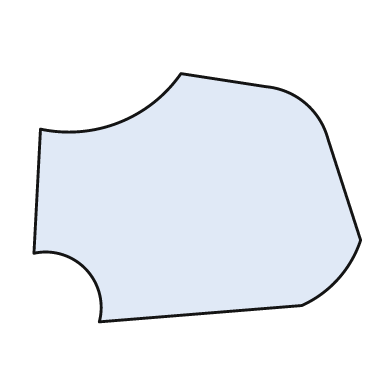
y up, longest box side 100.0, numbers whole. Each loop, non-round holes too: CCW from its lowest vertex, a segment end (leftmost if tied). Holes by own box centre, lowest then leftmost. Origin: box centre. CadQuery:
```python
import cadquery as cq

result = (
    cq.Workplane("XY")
    .moveTo(-30.0, -38.0)
    .lineTo(32.0, -33.0)
    .threePointArc((43.0, -25.0), (50.0, -13.0))
    .lineTo(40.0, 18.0)
    .threePointArc((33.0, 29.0), (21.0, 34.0))
    .lineTo(-5.0, 38.0)
    .threePointArc((-24.0, 23.0), (-48.0, 21.0))
    .lineTo(-50.0, -17.0)
    .threePointArc((-34.0, -22.0), (-30.0, -38.0))
    .close()
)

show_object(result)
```